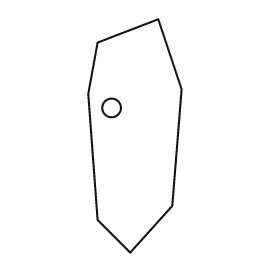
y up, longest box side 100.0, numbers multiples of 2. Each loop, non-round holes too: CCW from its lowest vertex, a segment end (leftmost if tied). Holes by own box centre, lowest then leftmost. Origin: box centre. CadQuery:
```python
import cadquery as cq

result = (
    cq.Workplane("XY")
    .moveTo(-2.0, -50.0)
    .lineTo(16.0, -30.0)
    .lineTo(20.0, 20.0)
    .lineTo(10.0, 50.0)
    .lineTo(-16.0, 40.0)
    .lineTo(-20.0, 18.0)
    .lineTo(-16.0, -36.0)
    .close()
    .moveTo(-10.0, 12.0)
    .circle(4.0)
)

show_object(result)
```